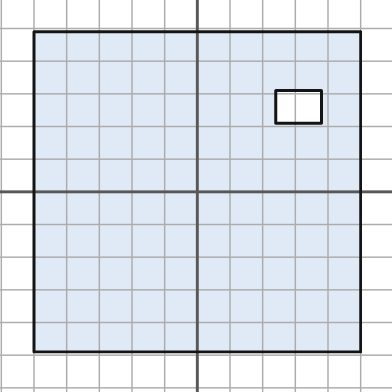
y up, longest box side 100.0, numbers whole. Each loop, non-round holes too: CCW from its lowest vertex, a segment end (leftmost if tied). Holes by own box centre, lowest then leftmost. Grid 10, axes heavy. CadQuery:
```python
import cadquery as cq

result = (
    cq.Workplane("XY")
    .moveTo(-50.0, -49.0)
    .lineTo(50.0, -49.0)
    .lineTo(50.0, 49.0)
    .lineTo(-50.0, 49.0)
    .close()
    .moveTo(24.0, 21.0)
    .lineTo(38.0, 21.0)
    .lineTo(38.0, 31.0)
    .lineTo(24.0, 31.0)
    .close()
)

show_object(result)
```